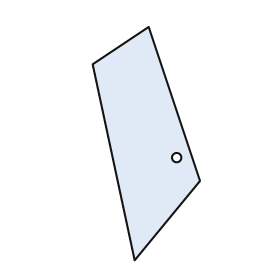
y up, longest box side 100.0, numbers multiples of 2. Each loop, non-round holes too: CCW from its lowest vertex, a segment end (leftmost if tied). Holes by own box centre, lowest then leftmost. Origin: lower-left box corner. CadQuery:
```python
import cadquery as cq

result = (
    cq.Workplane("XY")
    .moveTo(18.0, 0.0)
    .lineTo(46.0, 34.0)
    .lineTo(24.0, 100.0)
    .lineTo(0.0, 84.0)
    .close()
    .moveTo(36.0, 44.0)
    .circle(2.0)
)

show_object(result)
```